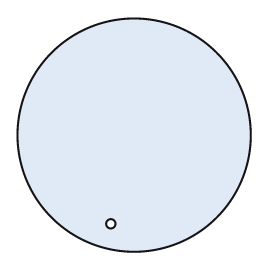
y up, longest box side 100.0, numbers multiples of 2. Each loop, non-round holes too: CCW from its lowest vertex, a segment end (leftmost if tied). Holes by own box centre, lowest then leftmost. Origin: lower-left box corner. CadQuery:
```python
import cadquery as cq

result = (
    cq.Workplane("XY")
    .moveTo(50.0, 50.0)
    .circle(50.0)
    .moveTo(40.0, 12.0)
    .circle(2.0)
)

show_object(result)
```